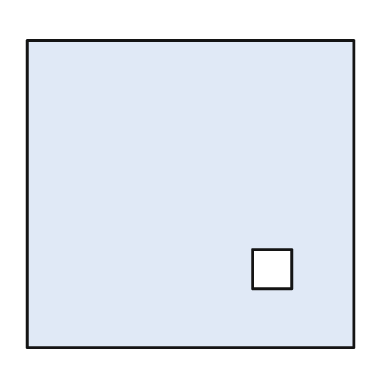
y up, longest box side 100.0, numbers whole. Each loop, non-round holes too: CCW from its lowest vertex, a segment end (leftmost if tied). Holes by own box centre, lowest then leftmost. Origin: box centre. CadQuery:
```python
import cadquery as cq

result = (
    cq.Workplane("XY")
    .moveTo(-50.0, -47.0)
    .lineTo(50.0, -47.0)
    .lineTo(50.0, 47.0)
    .lineTo(-50.0, 47.0)
    .close()
    .moveTo(19.0, -29.0)
    .lineTo(31.0, -29.0)
    .lineTo(31.0, -17.0)
    .lineTo(19.0, -17.0)
    .close()
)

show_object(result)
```